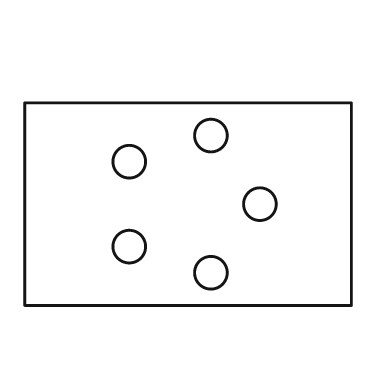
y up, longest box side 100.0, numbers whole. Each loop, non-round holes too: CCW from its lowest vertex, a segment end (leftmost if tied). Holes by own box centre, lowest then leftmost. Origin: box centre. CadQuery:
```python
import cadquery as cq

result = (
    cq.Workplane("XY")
    .moveTo(-50.0, -31.0)
    .lineTo(50.0, -31.0)
    .lineTo(50.0, 31.0)
    .lineTo(-50.0, 31.0)
    .close()
    .moveTo(7.0, -21.0)
    .circle(5.0)
    .moveTo(-18.0, -13.0)
    .circle(5.0)
    .moveTo(22.0, 0.0)
    .circle(5.0)
    .moveTo(-18.0, 13.0)
    .circle(5.0)
    .moveTo(7.0, 21.0)
    .circle(5.0)
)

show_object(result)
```